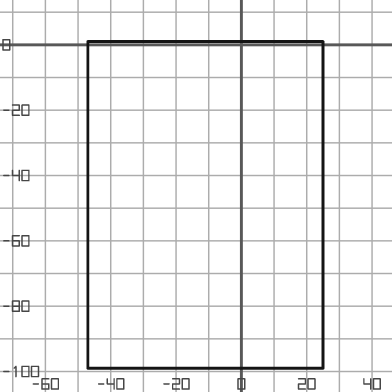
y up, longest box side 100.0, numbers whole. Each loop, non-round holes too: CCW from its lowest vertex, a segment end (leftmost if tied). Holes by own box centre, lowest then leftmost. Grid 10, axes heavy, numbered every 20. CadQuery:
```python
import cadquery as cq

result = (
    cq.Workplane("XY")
    .moveTo(-47.0, -99.0)
    .lineTo(25.0, -99.0)
    .lineTo(25.0, 1.0)
    .lineTo(-47.0, 1.0)
    .close()
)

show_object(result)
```